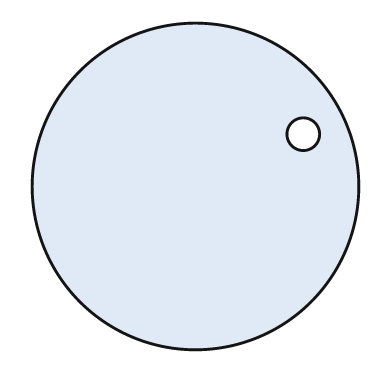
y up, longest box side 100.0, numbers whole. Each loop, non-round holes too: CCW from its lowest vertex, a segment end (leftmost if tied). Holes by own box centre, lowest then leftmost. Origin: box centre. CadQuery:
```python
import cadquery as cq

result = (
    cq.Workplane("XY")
    .moveTo(0.0, 0.0)
    .circle(50.0)
    .moveTo(33.0, 16.0)
    .circle(5.0)
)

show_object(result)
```